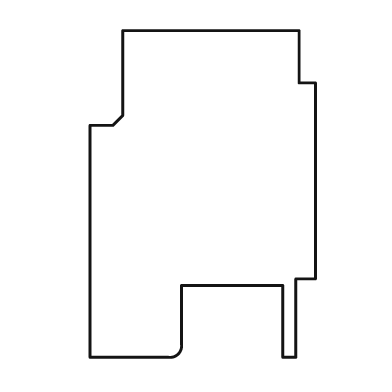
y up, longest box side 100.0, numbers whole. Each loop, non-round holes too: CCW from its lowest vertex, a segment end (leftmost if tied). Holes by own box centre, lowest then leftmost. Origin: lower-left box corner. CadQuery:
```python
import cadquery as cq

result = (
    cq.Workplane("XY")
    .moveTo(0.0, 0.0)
    .lineTo(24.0, 0.0)
    .threePointArc((27.0, 1.0), (28.0, 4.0))
    .lineTo(28.0, 22.0)
    .lineTo(59.0, 22.0)
    .lineTo(59.0, 0.0)
    .lineTo(63.0, 0.0)
    .lineTo(63.0, 24.0)
    .lineTo(69.0, 24.0)
    .lineTo(69.0, 84.0)
    .lineTo(64.0, 84.0)
    .lineTo(64.0, 100.0)
    .lineTo(10.0, 100.0)
    .lineTo(10.0, 74.0)
    .lineTo(7.0, 71.0)
    .lineTo(0.0, 71.0)
    .close()
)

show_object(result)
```